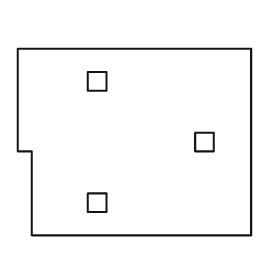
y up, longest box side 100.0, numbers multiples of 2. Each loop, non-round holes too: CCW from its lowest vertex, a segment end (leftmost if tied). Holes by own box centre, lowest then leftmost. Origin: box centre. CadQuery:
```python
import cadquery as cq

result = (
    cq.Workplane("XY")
    .moveTo(-44.0, -40.0)
    .lineTo(50.0, -40.0)
    .lineTo(50.0, 40.0)
    .lineTo(-50.0, 40.0)
    .lineTo(-50.0, -4.0)
    .lineTo(-44.0, -4.0)
    .close()
    .moveTo(-20.0, -30.0)
    .lineTo(-12.0, -30.0)
    .lineTo(-12.0, -22.0)
    .lineTo(-20.0, -22.0)
    .close()
    .moveTo(26.0, -4.0)
    .lineTo(34.0, -4.0)
    .lineTo(34.0, 4.0)
    .lineTo(26.0, 4.0)
    .close()
    .moveTo(-20.0, 22.0)
    .lineTo(-12.0, 22.0)
    .lineTo(-12.0, 30.0)
    .lineTo(-20.0, 30.0)
    .close()
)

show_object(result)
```